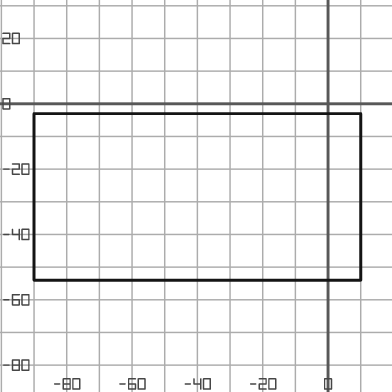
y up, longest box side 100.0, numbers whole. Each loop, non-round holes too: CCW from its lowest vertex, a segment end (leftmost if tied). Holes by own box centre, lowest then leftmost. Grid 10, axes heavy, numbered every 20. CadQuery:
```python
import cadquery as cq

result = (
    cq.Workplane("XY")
    .moveTo(-90.0, -54.0)
    .lineTo(10.0, -54.0)
    .lineTo(10.0, -3.0)
    .lineTo(-90.0, -3.0)
    .close()
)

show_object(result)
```